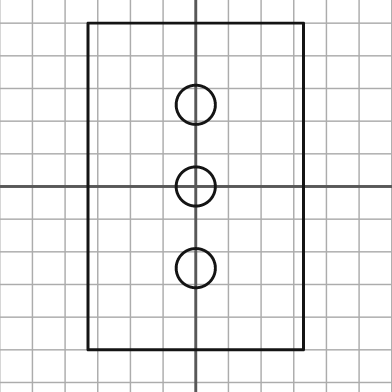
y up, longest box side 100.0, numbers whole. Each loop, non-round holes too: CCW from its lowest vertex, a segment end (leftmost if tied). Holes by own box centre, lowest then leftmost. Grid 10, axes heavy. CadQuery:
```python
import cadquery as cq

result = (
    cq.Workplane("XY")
    .moveTo(-33.0, -50.0)
    .lineTo(33.0, -50.0)
    .lineTo(33.0, 50.0)
    .lineTo(-33.0, 50.0)
    .close()
    .moveTo(0.0, -25.0)
    .circle(6.0)
    .moveTo(0.0, 0.0)
    .circle(6.0)
    .moveTo(0.0, 25.0)
    .circle(6.0)
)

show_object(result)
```